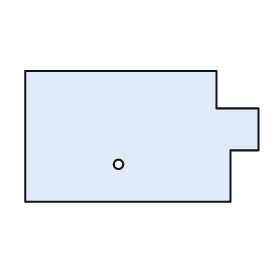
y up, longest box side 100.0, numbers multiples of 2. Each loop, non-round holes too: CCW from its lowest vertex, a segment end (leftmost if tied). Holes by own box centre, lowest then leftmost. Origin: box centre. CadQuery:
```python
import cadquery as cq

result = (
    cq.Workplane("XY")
    .moveTo(-50.0, -28.0)
    .lineTo(38.0, -28.0)
    .lineTo(38.0, -6.0)
    .lineTo(50.0, -6.0)
    .lineTo(50.0, 12.0)
    .lineTo(32.0, 12.0)
    .lineTo(32.0, 28.0)
    .lineTo(-50.0, 28.0)
    .close()
    .moveTo(-10.0, -12.0)
    .circle(2.0)
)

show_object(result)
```